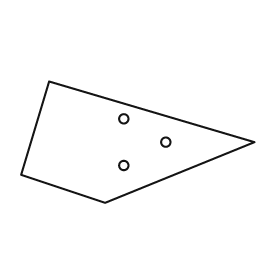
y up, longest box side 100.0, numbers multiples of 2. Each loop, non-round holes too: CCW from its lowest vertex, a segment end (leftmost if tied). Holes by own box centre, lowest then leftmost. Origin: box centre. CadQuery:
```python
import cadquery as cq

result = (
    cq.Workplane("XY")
    .moveTo(-14.0, -26.0)
    .lineTo(50.0, 0.0)
    .lineTo(-38.0, 26.0)
    .lineTo(-50.0, -14.0)
    .close()
    .moveTo(-6.0, -10.0)
    .circle(2.0)
    .moveTo(12.0, 0.0)
    .circle(2.0)
    .moveTo(-6.0, 10.0)
    .circle(2.0)
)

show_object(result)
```